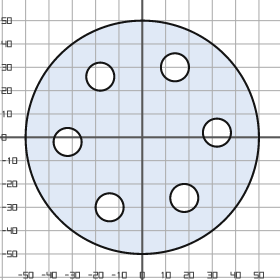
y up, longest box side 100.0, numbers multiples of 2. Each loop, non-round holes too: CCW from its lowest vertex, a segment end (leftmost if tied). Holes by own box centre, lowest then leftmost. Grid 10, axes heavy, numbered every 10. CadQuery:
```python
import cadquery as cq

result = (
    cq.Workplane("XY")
    .moveTo(0.0, 0.0)
    .circle(50.0)
    .moveTo(-14.0, -30.0)
    .circle(6.0)
    .moveTo(18.0, -26.0)
    .circle(6.0)
    .moveTo(-32.0, -2.0)
    .circle(6.0)
    .moveTo(32.0, 2.0)
    .circle(6.0)
    .moveTo(-18.0, 26.0)
    .circle(6.0)
    .moveTo(14.0, 30.0)
    .circle(6.0)
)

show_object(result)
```